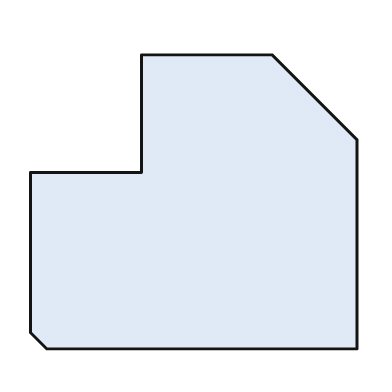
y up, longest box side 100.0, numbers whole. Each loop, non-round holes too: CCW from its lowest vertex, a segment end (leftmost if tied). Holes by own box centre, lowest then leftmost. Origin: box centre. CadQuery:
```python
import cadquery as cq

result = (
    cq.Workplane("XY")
    .moveTo(-45.0, -45.0)
    .lineTo(50.0, -45.0)
    .lineTo(50.0, 19.0)
    .lineTo(24.0, 45.0)
    .lineTo(-16.0, 45.0)
    .lineTo(-16.0, 9.0)
    .lineTo(-50.0, 9.0)
    .lineTo(-50.0, -40.0)
    .close()
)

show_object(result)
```